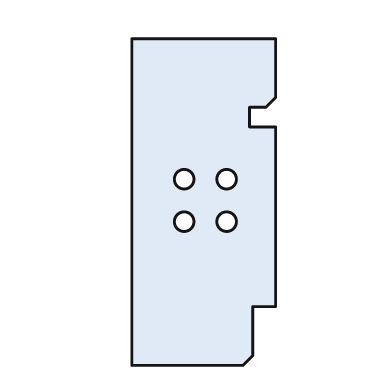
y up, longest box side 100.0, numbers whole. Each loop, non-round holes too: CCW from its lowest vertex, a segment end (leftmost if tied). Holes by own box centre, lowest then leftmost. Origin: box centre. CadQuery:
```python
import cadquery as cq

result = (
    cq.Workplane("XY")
    .moveTo(-22.0, -50.0)
    .lineTo(12.0, -50.0)
    .lineTo(15.0, -47.0)
    .lineTo(15.0, -32.0)
    .lineTo(22.0, -32.0)
    .lineTo(22.0, 23.0)
    .lineTo(14.0, 23.0)
    .lineTo(14.0, 29.0)
    .lineTo(19.0, 29.0)
    .lineTo(22.0, 32.0)
    .lineTo(22.0, 50.0)
    .lineTo(-22.0, 50.0)
    .close()
    .moveTo(-6.0, -6.0)
    .circle(3.0)
    .moveTo(7.0, -6.0)
    .circle(3.0)
    .moveTo(-6.0, 7.0)
    .circle(3.0)
    .moveTo(7.0, 7.0)
    .circle(3.0)
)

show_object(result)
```